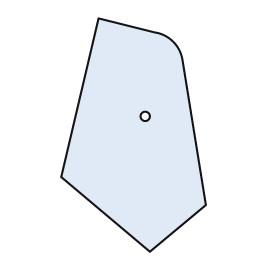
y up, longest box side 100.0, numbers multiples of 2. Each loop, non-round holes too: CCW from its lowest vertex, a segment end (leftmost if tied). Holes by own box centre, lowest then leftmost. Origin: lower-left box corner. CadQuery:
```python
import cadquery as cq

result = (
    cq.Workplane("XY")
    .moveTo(38.0, 0.0)
    .lineTo(62.0, 20.0)
    .lineTo(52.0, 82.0)
    .threePointArc((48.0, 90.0), (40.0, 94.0))
    .lineTo(16.0, 100.0)
    .lineTo(0.0, 32.0)
    .close()
    .moveTo(36.0, 58.0)
    .circle(2.0)
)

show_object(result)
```